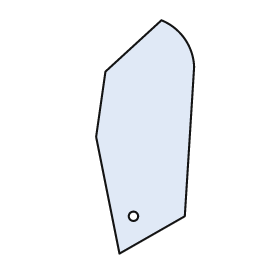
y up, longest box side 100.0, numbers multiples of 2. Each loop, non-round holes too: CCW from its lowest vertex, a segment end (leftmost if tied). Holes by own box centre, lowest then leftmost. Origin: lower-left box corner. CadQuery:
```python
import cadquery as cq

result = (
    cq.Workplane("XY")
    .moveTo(10.0, 0.0)
    .lineTo(38.0, 16.0)
    .lineTo(42.0, 80.0)
    .threePointArc((38.0, 92.0), (28.0, 100.0))
    .lineTo(4.0, 78.0)
    .lineTo(0.0, 50.0)
    .close()
    .moveTo(16.0, 16.0)
    .circle(2.0)
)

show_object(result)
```